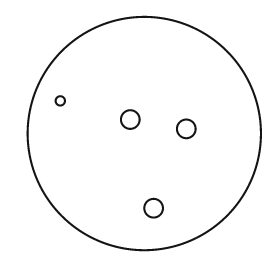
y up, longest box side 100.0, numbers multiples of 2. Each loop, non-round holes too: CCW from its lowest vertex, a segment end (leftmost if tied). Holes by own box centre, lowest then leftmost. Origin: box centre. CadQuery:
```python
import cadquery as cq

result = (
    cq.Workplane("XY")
    .moveTo(0.0, 0.0)
    .circle(50.0)
    .moveTo(4.0, -32.0)
    .circle(4.0)
    .moveTo(18.0, 2.0)
    .circle(4.0)
    .moveTo(-6.0, 6.0)
    .circle(4.0)
    .moveTo(-36.0, 14.0)
    .circle(2.0)
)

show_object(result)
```